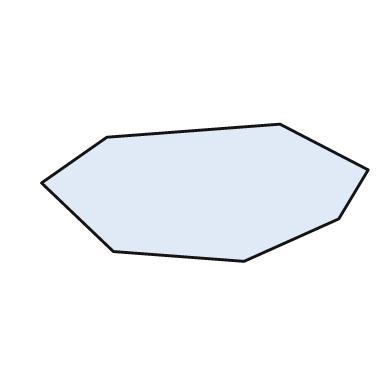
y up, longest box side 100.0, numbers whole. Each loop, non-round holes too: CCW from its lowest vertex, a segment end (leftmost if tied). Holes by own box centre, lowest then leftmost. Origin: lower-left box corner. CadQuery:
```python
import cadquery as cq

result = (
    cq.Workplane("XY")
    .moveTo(62.0, 0.0)
    .lineTo(91.0, 13.0)
    .lineTo(100.0, 28.0)
    .lineTo(73.0, 42.0)
    .lineTo(20.0, 38.0)
    .lineTo(0.0, 24.0)
    .lineTo(22.0, 3.0)
    .close()
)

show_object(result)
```